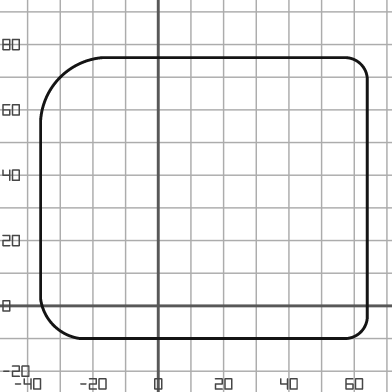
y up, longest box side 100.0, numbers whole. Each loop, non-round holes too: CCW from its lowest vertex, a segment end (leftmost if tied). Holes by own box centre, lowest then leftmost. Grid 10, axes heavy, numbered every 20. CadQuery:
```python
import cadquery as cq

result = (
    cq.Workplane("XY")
    .moveTo(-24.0, -10.0)
    .lineTo(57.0, -10.0)
    .threePointArc((62.0, -8.0), (64.0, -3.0))
    .lineTo(64.0, 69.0)
    .threePointArc((62.0, 74.0), (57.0, 76.0))
    .lineTo(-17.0, 76.0)
    .threePointArc((-30.0, 70.0), (-36.0, 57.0))
    .lineTo(-36.0, 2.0)
    .threePointArc((-32.0, -6.0), (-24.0, -10.0))
    .close()
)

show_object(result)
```